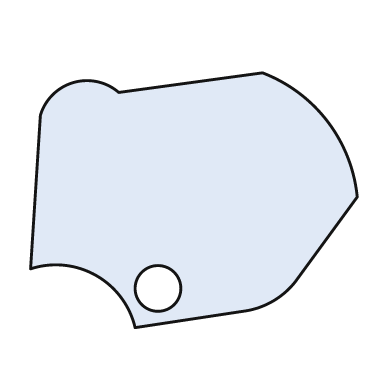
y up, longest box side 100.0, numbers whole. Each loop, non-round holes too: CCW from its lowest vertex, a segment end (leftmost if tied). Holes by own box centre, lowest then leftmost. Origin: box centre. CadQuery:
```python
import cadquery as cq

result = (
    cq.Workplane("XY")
    .moveTo(-18.0, -39.0)
    .lineTo(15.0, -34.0)
    .threePointArc((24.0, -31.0), (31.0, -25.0))
    .lineTo(50.0, 1.0)
    .threePointArc((41.0, 24.0), (21.0, 39.0))
    .lineTo(-23.0, 33.0)
    .threePointArc((-37.0, 36.0), (-47.0, 26.0))
    .lineTo(-50.0, -21.0)
    .threePointArc((-30.0, -23.0), (-18.0, -39.0))
    .close()
    .moveTo(-11.0, -27.0)
    .circle(7.0)
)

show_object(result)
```